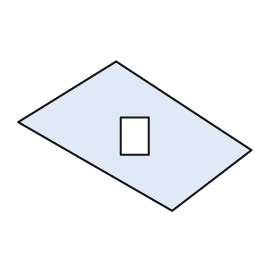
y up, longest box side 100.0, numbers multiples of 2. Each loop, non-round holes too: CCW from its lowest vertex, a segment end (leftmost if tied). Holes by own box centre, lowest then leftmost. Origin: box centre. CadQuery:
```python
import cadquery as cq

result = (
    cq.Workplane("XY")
    .moveTo(16.0, -32.0)
    .lineTo(50.0, -6.0)
    .lineTo(-8.0, 32.0)
    .lineTo(-50.0, 6.0)
    .close()
    .moveTo(-6.0, -8.0)
    .lineTo(6.0, -8.0)
    .lineTo(6.0, 8.0)
    .lineTo(-6.0, 8.0)
    .close()
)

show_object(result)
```